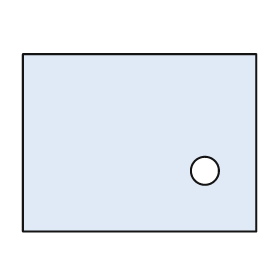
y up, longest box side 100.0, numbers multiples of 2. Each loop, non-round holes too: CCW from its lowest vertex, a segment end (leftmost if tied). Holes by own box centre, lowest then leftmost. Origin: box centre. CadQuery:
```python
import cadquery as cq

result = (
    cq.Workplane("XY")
    .moveTo(-50.0, -38.0)
    .lineTo(50.0, -38.0)
    .lineTo(50.0, 38.0)
    .lineTo(-50.0, 38.0)
    .close()
    .moveTo(28.0, -12.0)
    .circle(6.0)
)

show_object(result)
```